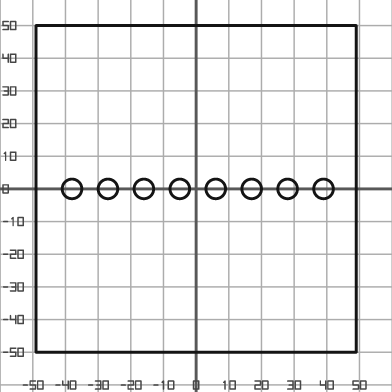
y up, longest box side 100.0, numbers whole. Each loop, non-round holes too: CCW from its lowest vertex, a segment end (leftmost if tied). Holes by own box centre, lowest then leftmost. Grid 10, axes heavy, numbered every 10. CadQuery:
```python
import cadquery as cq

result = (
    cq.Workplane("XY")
    .moveTo(-49.0, -50.0)
    .lineTo(49.0, -50.0)
    .lineTo(49.0, 50.0)
    .lineTo(-49.0, 50.0)
    .close()
    .moveTo(-38.0, 0.0)
    .circle(3.0)
    .moveTo(-27.0, 0.0)
    .circle(3.0)
    .moveTo(-16.0, 0.0)
    .circle(3.0)
    .moveTo(-5.0, 0.0)
    .circle(3.0)
    .moveTo(6.0, 0.0)
    .circle(3.0)
    .moveTo(17.0, 0.0)
    .circle(3.0)
    .moveTo(28.0, 0.0)
    .circle(3.0)
    .moveTo(39.0, 0.0)
    .circle(3.0)
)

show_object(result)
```